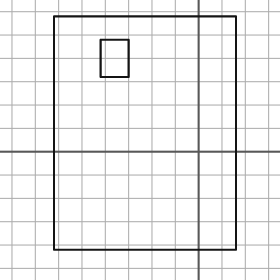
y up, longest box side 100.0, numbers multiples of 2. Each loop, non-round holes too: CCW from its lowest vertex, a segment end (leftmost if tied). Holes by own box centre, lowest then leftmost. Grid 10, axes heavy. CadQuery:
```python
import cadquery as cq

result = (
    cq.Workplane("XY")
    .moveTo(-62.0, -42.0)
    .lineTo(16.0, -42.0)
    .lineTo(16.0, 58.0)
    .lineTo(-62.0, 58.0)
    .close()
    .moveTo(-42.0, 32.0)
    .lineTo(-30.0, 32.0)
    .lineTo(-30.0, 48.0)
    .lineTo(-42.0, 48.0)
    .close()
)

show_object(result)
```